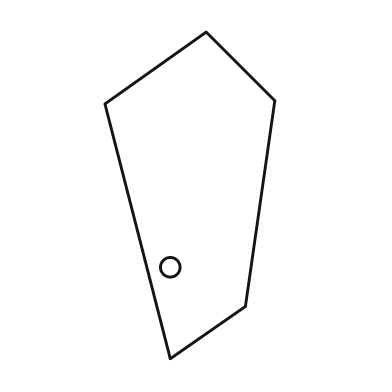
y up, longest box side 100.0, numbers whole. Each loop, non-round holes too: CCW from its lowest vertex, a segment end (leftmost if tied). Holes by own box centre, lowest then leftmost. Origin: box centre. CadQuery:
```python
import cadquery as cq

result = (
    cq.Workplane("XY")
    .moveTo(-6.0, -50.0)
    .lineTo(17.0, -34.0)
    .lineTo(26.0, 29.0)
    .lineTo(5.0, 50.0)
    .lineTo(-26.0, 28.0)
    .close()
    .moveTo(-6.0, -22.0)
    .circle(3.0)
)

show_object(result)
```